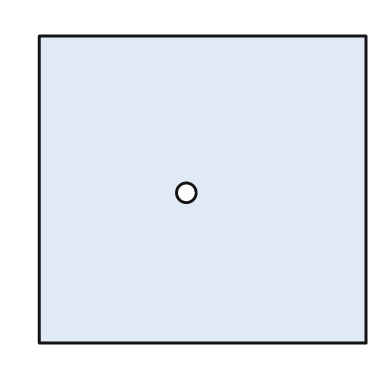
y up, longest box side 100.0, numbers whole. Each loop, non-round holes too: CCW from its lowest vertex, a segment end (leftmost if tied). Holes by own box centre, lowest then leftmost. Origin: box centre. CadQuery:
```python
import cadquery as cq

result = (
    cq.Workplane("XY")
    .moveTo(-50.0, -47.0)
    .lineTo(50.0, -47.0)
    .lineTo(50.0, 47.0)
    .lineTo(-50.0, 47.0)
    .close()
    .moveTo(-5.0, -1.0)
    .circle(3.0)
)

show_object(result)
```